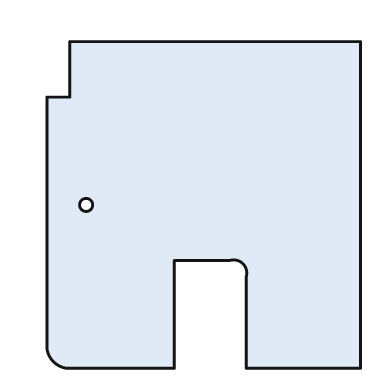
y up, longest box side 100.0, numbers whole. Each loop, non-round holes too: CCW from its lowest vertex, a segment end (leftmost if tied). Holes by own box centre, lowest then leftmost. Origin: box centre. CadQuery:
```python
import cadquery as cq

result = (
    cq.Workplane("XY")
    .moveTo(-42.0, -50.0)
    .lineTo(-9.0, -50.0)
    .lineTo(-9.0, -17.0)
    .lineTo(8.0, -17.0)
    .threePointArc((12.0, -18.0), (13.0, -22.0))
    .lineTo(13.0, -50.0)
    .lineTo(48.0, -50.0)
    .lineTo(48.0, 50.0)
    .lineTo(-41.0, 50.0)
    .lineTo(-41.0, 33.0)
    .lineTo(-48.0, 33.0)
    .lineTo(-48.0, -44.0)
    .threePointArc((-46.0, -48.0), (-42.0, -50.0))
    .close()
    .moveTo(-36.0, 0.0)
    .circle(2.0)
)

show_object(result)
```